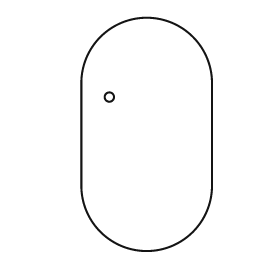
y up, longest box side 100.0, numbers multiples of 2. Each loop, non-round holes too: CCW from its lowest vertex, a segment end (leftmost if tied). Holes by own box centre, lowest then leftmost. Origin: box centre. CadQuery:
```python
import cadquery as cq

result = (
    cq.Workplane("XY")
    .moveTo(-28.0, -22.0)
    .threePointArc((0.0, -50.0), (28.0, -22.0))
    .lineTo(28.0, 22.0)
    .threePointArc((0.0, 50.0), (-28.0, 22.0))
    .close()
    .moveTo(-16.0, 16.0)
    .circle(2.0)
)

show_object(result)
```